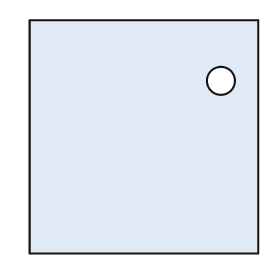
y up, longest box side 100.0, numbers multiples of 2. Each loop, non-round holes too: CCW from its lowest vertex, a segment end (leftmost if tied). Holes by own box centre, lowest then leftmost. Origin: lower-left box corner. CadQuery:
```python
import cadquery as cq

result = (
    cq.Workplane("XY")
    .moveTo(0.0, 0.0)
    .lineTo(98.0, 0.0)
    .lineTo(98.0, 100.0)
    .lineTo(0.0, 100.0)
    .close()
    .moveTo(82.0, 74.0)
    .circle(6.0)
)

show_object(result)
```